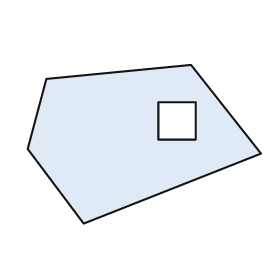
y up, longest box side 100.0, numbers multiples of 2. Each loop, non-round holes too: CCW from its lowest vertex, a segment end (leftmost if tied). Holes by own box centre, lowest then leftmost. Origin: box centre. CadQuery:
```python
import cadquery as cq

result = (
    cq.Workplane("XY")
    .moveTo(-26.0, -34.0)
    .lineTo(50.0, -4.0)
    .lineTo(20.0, 34.0)
    .lineTo(-42.0, 28.0)
    .lineTo(-50.0, -2.0)
    .close()
    .moveTo(6.0, 2.0)
    .lineTo(22.0, 2.0)
    .lineTo(22.0, 18.0)
    .lineTo(6.0, 18.0)
    .close()
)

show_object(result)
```